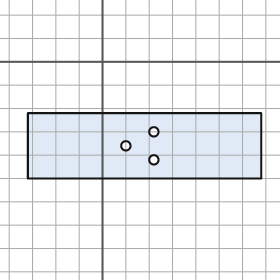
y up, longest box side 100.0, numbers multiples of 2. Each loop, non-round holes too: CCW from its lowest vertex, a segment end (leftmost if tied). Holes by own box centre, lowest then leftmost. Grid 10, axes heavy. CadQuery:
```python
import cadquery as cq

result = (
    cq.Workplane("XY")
    .moveTo(-32.0, -50.0)
    .lineTo(68.0, -50.0)
    .lineTo(68.0, -22.0)
    .lineTo(-32.0, -22.0)
    .close()
    .moveTo(22.0, -42.0)
    .circle(2.0)
    .moveTo(10.0, -36.0)
    .circle(2.0)
    .moveTo(22.0, -30.0)
    .circle(2.0)
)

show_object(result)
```